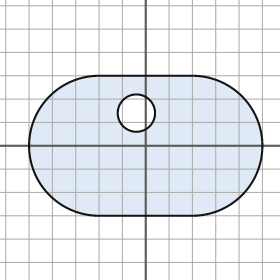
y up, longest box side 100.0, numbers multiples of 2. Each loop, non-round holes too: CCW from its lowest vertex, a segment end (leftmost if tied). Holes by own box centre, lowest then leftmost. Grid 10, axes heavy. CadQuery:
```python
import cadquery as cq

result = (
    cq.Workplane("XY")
    .moveTo(-20.0, -30.0)
    .lineTo(20.0, -30.0)
    .threePointArc((50.0, 0.0), (20.0, 30.0))
    .lineTo(-20.0, 30.0)
    .threePointArc((-50.0, 0.0), (-20.0, -30.0))
    .close()
    .moveTo(-4.0, 14.0)
    .circle(8.0)
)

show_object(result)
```